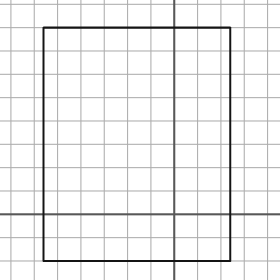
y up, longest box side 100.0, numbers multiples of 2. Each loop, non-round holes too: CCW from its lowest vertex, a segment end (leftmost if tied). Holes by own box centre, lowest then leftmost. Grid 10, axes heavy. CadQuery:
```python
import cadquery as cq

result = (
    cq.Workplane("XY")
    .moveTo(-56.0, -20.0)
    .lineTo(24.0, -20.0)
    .lineTo(24.0, 80.0)
    .lineTo(-56.0, 80.0)
    .close()
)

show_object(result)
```